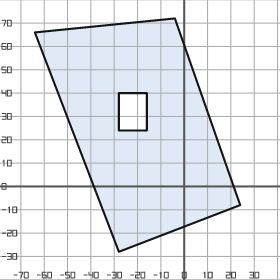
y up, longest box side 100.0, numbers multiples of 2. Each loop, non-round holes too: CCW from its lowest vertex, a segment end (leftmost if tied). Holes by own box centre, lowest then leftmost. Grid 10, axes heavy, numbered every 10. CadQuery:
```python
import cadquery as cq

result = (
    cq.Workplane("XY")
    .moveTo(-28.0, -28.0)
    .lineTo(24.0, -8.0)
    .lineTo(-4.0, 72.0)
    .lineTo(-64.0, 66.0)
    .close()
    .moveTo(-28.0, 24.0)
    .lineTo(-16.0, 24.0)
    .lineTo(-16.0, 40.0)
    .lineTo(-28.0, 40.0)
    .close()
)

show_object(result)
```